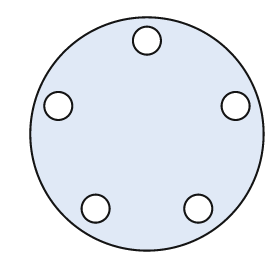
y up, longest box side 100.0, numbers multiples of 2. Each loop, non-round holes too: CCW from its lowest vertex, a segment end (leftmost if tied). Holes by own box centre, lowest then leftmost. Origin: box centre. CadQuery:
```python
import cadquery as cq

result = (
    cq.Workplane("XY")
    .moveTo(0.0, 0.0)
    .circle(50.0)
    .moveTo(-22.0, -32.0)
    .circle(6.0)
    .moveTo(22.0, -32.0)
    .circle(6.0)
    .moveTo(-38.0, 12.0)
    .circle(6.0)
    .moveTo(38.0, 12.0)
    .circle(6.0)
    .moveTo(0.0, 40.0)
    .circle(6.0)
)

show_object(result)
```